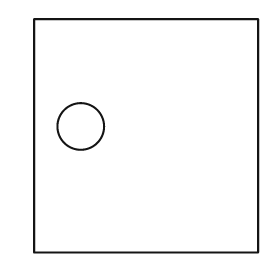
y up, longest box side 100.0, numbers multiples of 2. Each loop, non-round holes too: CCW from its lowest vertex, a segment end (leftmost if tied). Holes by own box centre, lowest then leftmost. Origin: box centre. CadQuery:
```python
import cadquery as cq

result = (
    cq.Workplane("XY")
    .moveTo(-48.0, -50.0)
    .lineTo(48.0, -50.0)
    .lineTo(48.0, 50.0)
    .lineTo(-48.0, 50.0)
    .close()
    .moveTo(-28.0, 4.0)
    .circle(10.0)
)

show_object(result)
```